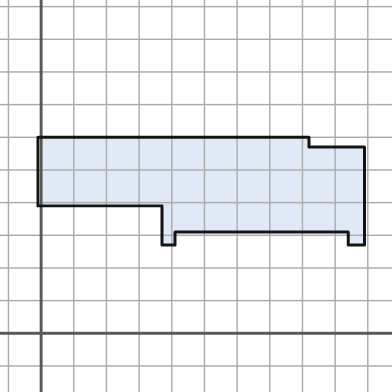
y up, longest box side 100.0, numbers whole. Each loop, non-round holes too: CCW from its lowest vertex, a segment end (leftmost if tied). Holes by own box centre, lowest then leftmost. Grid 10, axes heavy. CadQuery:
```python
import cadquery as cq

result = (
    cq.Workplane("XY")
    .moveTo(37.0, 27.0)
    .lineTo(41.0, 27.0)
    .lineTo(41.0, 31.0)
    .lineTo(94.0, 31.0)
    .lineTo(94.0, 27.0)
    .lineTo(99.0, 27.0)
    .lineTo(99.0, 57.0)
    .lineTo(82.0, 57.0)
    .lineTo(82.0, 60.0)
    .lineTo(-1.0, 60.0)
    .lineTo(-1.0, 39.0)
    .lineTo(37.0, 39.0)
    .close()
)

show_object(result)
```